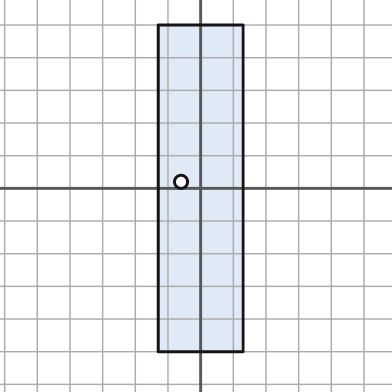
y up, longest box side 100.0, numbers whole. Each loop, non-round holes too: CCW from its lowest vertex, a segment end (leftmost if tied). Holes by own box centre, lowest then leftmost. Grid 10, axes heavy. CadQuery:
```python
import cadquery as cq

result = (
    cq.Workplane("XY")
    .moveTo(-13.0, -50.0)
    .lineTo(13.0, -50.0)
    .lineTo(13.0, 50.0)
    .lineTo(-13.0, 50.0)
    .close()
    .moveTo(-6.0, 2.0)
    .circle(2.0)
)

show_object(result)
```